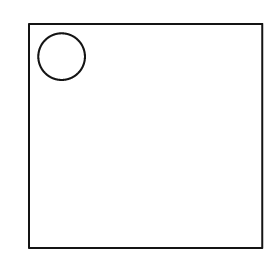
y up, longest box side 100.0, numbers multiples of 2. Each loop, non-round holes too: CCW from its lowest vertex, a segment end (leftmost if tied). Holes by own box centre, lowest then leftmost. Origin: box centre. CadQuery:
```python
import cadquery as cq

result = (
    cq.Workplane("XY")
    .moveTo(-50.0, -48.0)
    .lineTo(50.0, -48.0)
    .lineTo(50.0, 48.0)
    .lineTo(-50.0, 48.0)
    .close()
    .moveTo(-36.0, 34.0)
    .circle(10.0)
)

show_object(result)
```